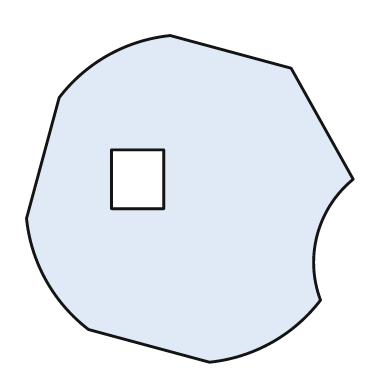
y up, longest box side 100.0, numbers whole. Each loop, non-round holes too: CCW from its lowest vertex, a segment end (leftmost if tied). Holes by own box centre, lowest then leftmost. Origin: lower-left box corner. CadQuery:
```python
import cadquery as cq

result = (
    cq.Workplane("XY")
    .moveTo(56.0, 0.0)
    .threePointArc((75.0, 6.0), (90.0, 19.0))
    .threePointArc((89.0, 39.0), (100.0, 56.0))
    .lineTo(81.0, 90.0)
    .lineTo(44.0, 100.0)
    .threePointArc((25.0, 94.0), (10.0, 81.0))
    .lineTo(0.0, 44.0)
    .threePointArc((6.0, 25.0), (19.0, 10.0))
    .close()
    .moveTo(26.0, 47.0)
    .lineTo(42.0, 47.0)
    .lineTo(42.0, 65.0)
    .lineTo(26.0, 65.0)
    .close()
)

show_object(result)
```